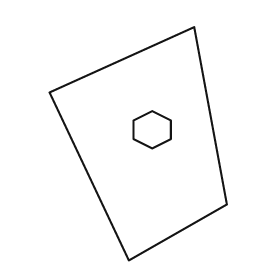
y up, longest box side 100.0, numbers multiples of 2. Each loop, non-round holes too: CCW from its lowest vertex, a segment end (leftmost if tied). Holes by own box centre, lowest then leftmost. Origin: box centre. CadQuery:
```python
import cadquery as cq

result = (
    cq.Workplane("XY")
    .moveTo(-4.0, -50.0)
    .lineTo(38.0, -26.0)
    .lineTo(24.0, 50.0)
    .lineTo(-38.0, 22.0)
    .close()
    .moveTo(6.0, -2.0)
    .lineTo(14.0, 2.0)
    .lineTo(14.0, 10.0)
    .lineTo(6.0, 14.0)
    .lineTo(-2.0, 10.0)
    .lineTo(-2.0, 2.0)
    .close()
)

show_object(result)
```